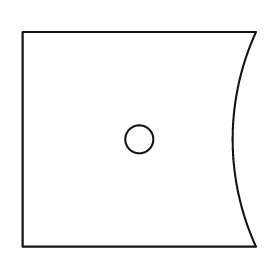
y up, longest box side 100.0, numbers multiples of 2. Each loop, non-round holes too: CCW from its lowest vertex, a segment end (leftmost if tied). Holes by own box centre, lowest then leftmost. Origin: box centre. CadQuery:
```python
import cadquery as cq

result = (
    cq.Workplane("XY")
    .moveTo(-50.0, -46.0)
    .lineTo(50.0, -46.0)
    .threePointArc((40.0, 0.0), (50.0, 46.0))
    .lineTo(-50.0, 46.0)
    .close()
    .moveTo(0.0, 0.0)
    .circle(6.0)
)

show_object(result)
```